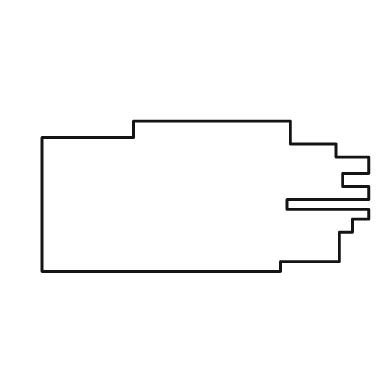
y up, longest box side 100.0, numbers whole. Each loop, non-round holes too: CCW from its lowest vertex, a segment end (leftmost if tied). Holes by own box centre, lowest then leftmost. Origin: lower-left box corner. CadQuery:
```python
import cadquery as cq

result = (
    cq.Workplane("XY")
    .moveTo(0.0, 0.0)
    .lineTo(73.0, 0.0)
    .lineTo(73.0, 3.0)
    .lineTo(91.0, 3.0)
    .lineTo(91.0, 12.0)
    .lineTo(95.0, 12.0)
    .lineTo(95.0, 16.0)
    .lineTo(100.0, 16.0)
    .lineTo(100.0, 19.0)
    .lineTo(75.0, 19.0)
    .lineTo(75.0, 22.0)
    .lineTo(100.0, 22.0)
    .lineTo(100.0, 26.0)
    .lineTo(92.0, 26.0)
    .lineTo(92.0, 30.0)
    .lineTo(100.0, 30.0)
    .lineTo(100.0, 35.0)
    .lineTo(90.0, 35.0)
    .lineTo(90.0, 39.0)
    .lineTo(76.0, 39.0)
    .lineTo(76.0, 46.0)
    .lineTo(28.0, 46.0)
    .lineTo(28.0, 41.0)
    .lineTo(0.0, 41.0)
    .close()
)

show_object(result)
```